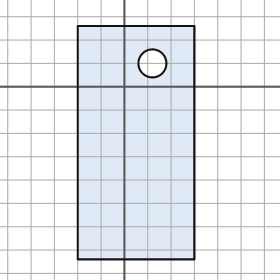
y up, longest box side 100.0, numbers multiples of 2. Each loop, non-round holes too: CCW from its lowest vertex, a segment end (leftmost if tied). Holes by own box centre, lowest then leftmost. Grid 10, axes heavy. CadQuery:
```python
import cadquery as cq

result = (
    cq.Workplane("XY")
    .moveTo(-20.0, -74.0)
    .lineTo(30.0, -74.0)
    .lineTo(30.0, 26.0)
    .lineTo(-20.0, 26.0)
    .close()
    .moveTo(12.0, 10.0)
    .circle(6.0)
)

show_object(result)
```